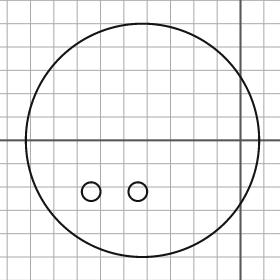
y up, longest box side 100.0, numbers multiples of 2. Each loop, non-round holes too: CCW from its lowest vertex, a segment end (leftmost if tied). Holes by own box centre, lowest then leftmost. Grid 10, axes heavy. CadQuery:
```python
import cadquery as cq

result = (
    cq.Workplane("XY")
    .moveTo(-42.0, 0.0)
    .circle(50.0)
    .moveTo(-64.0, -22.0)
    .circle(4.0)
    .moveTo(-44.0, -22.0)
    .circle(4.0)
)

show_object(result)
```